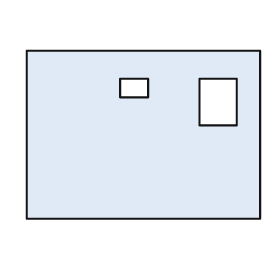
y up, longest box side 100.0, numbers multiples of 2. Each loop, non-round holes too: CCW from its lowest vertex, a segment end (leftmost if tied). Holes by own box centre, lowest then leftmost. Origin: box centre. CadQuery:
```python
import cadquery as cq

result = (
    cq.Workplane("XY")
    .moveTo(-50.0, -36.0)
    .lineTo(50.0, -36.0)
    .lineTo(50.0, 36.0)
    .lineTo(-50.0, 36.0)
    .close()
    .moveTo(24.0, 4.0)
    .lineTo(40.0, 4.0)
    .lineTo(40.0, 24.0)
    .lineTo(24.0, 24.0)
    .close()
    .moveTo(-10.0, 16.0)
    .lineTo(2.0, 16.0)
    .lineTo(2.0, 24.0)
    .lineTo(-10.0, 24.0)
    .close()
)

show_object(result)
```